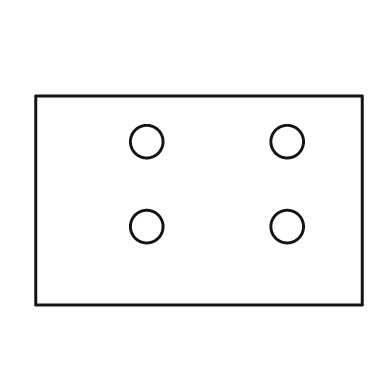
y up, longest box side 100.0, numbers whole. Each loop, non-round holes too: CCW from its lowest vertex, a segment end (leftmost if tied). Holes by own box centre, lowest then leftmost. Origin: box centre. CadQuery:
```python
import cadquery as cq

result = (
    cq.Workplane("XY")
    .moveTo(-50.0, -32.0)
    .lineTo(50.0, -32.0)
    .lineTo(50.0, 32.0)
    .lineTo(-50.0, 32.0)
    .close()
    .moveTo(-16.0, -8.0)
    .circle(5.0)
    .moveTo(27.0, -8.0)
    .circle(5.0)
    .moveTo(-16.0, 18.0)
    .circle(5.0)
    .moveTo(27.0, 18.0)
    .circle(5.0)
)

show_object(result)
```